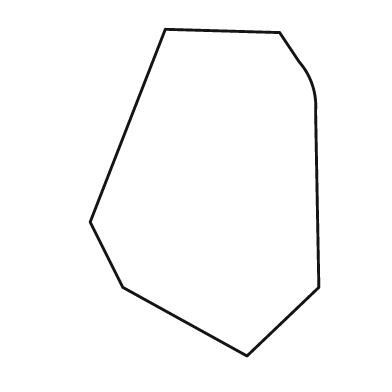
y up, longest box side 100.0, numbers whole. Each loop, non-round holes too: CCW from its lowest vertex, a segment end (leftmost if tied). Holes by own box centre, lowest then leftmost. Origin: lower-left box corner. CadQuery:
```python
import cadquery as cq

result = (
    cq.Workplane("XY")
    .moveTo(48.0, 0.0)
    .lineTo(70.0, 21.0)
    .lineTo(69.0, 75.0)
    .threePointArc((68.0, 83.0), (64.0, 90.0))
    .lineTo(58.0, 99.0)
    .lineTo(23.0, 100.0)
    .lineTo(0.0, 41.0)
    .lineTo(10.0, 21.0)
    .close()
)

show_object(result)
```